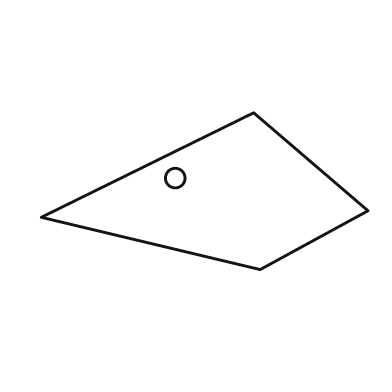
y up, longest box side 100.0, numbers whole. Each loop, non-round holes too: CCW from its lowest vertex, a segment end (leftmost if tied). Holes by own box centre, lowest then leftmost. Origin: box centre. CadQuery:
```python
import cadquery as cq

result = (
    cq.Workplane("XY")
    .moveTo(17.0, -24.0)
    .lineTo(50.0, -6.0)
    .lineTo(15.0, 24.0)
    .lineTo(-50.0, -8.0)
    .close()
    .moveTo(-9.0, 4.0)
    .circle(3.0)
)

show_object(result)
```